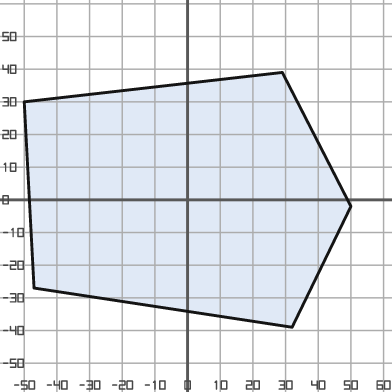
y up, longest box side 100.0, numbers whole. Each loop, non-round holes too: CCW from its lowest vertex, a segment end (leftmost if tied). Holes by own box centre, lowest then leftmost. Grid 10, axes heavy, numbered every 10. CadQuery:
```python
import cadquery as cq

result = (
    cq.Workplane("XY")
    .moveTo(32.0, -39.0)
    .lineTo(50.0, -2.0)
    .lineTo(29.0, 39.0)
    .lineTo(-50.0, 30.0)
    .lineTo(-47.0, -27.0)
    .close()
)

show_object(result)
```